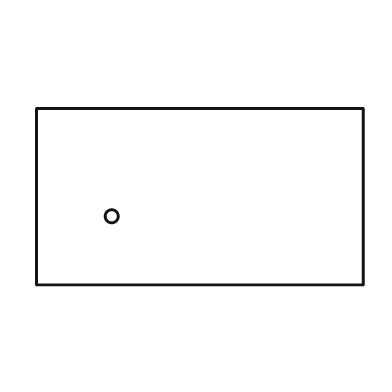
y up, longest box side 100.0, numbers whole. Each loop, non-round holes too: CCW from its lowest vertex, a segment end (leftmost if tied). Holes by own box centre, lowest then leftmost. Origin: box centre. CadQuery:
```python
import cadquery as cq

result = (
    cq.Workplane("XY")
    .moveTo(-50.0, -27.0)
    .lineTo(50.0, -27.0)
    .lineTo(50.0, 27.0)
    .lineTo(-50.0, 27.0)
    .close()
    .moveTo(-27.0, -6.0)
    .circle(2.0)
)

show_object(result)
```